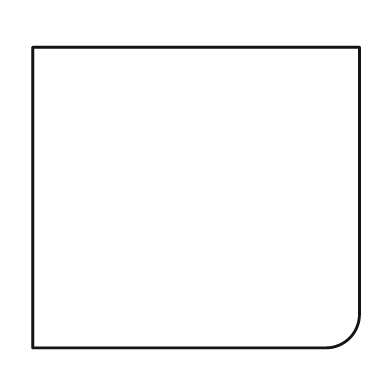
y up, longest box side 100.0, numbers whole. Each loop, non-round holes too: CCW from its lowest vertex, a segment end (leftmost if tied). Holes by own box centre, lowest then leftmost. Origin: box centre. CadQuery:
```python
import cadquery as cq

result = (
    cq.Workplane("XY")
    .moveTo(-50.0, -46.0)
    .lineTo(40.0, -46.0)
    .threePointArc((47.0, -43.0), (50.0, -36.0))
    .lineTo(50.0, 46.0)
    .lineTo(-50.0, 46.0)
    .close()
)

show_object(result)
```